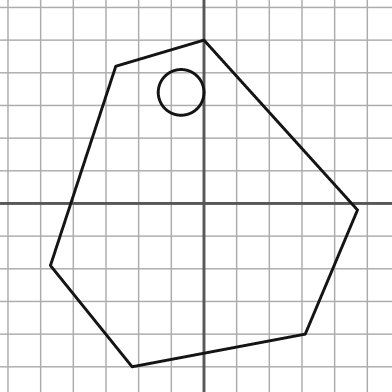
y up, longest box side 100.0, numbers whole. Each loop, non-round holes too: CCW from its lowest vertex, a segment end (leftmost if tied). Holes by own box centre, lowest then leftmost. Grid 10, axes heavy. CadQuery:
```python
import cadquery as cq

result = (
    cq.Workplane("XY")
    .moveTo(-22.0, -50.0)
    .lineTo(31.0, -40.0)
    .lineTo(47.0, -2.0)
    .lineTo(0.0, 50.0)
    .lineTo(-27.0, 42.0)
    .lineTo(-47.0, -19.0)
    .close()
    .moveTo(-7.0, 34.0)
    .circle(7.0)
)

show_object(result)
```